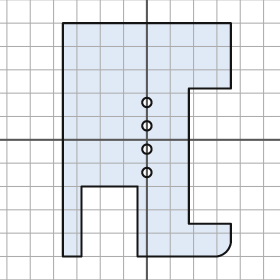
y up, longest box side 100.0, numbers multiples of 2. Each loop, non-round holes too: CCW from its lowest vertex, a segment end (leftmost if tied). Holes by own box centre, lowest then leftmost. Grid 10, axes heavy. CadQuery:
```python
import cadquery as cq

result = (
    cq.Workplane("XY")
    .moveTo(-36.0, -50.0)
    .lineTo(-28.0, -50.0)
    .lineTo(-28.0, -20.0)
    .lineTo(-4.0, -20.0)
    .lineTo(-4.0, -50.0)
    .lineTo(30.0, -50.0)
    .threePointArc((34.0, -48.0), (36.0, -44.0))
    .lineTo(36.0, -36.0)
    .lineTo(18.0, -36.0)
    .lineTo(18.0, 22.0)
    .lineTo(36.0, 22.0)
    .lineTo(36.0, 50.0)
    .lineTo(-36.0, 50.0)
    .close()
    .moveTo(0.0, -14.0)
    .circle(2.0)
    .moveTo(0.0, -4.0)
    .circle(2.0)
    .moveTo(0.0, 6.0)
    .circle(2.0)
    .moveTo(0.0, 16.0)
    .circle(2.0)
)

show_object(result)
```